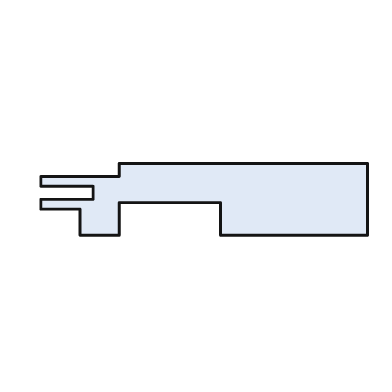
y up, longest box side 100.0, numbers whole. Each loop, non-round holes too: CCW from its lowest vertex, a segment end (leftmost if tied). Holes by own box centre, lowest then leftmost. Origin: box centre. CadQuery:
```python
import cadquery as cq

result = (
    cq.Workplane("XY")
    .moveTo(-38.0, -11.0)
    .lineTo(-26.0, -11.0)
    .lineTo(-26.0, -1.0)
    .lineTo(5.0, -1.0)
    .lineTo(5.0, -11.0)
    .lineTo(50.0, -11.0)
    .lineTo(50.0, 11.0)
    .lineTo(-26.0, 11.0)
    .lineTo(-26.0, 7.0)
    .lineTo(-50.0, 7.0)
    .lineTo(-50.0, 4.0)
    .lineTo(-34.0, 4.0)
    .lineTo(-34.0, 0.0)
    .lineTo(-50.0, 0.0)
    .lineTo(-50.0, -3.0)
    .lineTo(-38.0, -3.0)
    .close()
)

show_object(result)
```